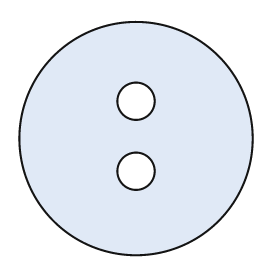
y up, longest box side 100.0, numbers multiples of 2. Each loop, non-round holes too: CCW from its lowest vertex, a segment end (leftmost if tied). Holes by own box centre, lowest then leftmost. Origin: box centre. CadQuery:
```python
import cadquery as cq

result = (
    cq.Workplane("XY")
    .moveTo(0.0, 0.0)
    .circle(50.0)
    .moveTo(0.0, -14.0)
    .circle(8.0)
    .moveTo(0.0, 16.0)
    .circle(8.0)
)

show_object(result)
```